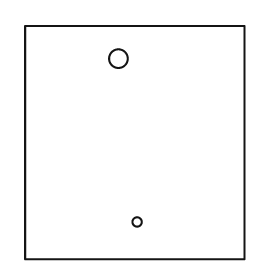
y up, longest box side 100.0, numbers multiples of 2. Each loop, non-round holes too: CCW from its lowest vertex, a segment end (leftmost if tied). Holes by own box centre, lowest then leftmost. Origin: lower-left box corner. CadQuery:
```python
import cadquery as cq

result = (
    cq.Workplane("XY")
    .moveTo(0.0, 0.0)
    .lineTo(94.0, 0.0)
    .lineTo(94.0, 100.0)
    .lineTo(0.0, 100.0)
    .close()
    .moveTo(48.0, 16.0)
    .circle(2.0)
    .moveTo(40.0, 86.0)
    .circle(4.0)
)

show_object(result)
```